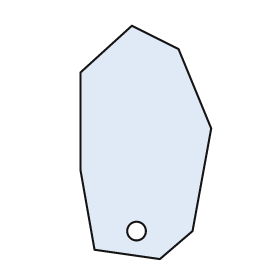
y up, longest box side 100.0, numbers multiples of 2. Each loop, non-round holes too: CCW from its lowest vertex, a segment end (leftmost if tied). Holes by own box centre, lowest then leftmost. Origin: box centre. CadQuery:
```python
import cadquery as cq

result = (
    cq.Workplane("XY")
    .moveTo(6.0, -50.0)
    .lineTo(20.0, -38.0)
    .lineTo(28.0, 6.0)
    .lineTo(14.0, 40.0)
    .lineTo(-6.0, 50.0)
    .lineTo(-28.0, 30.0)
    .lineTo(-28.0, -12.0)
    .lineTo(-22.0, -46.0)
    .close()
    .moveTo(-4.0, -38.0)
    .circle(4.0)
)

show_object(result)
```